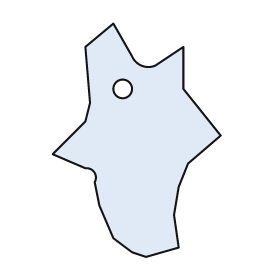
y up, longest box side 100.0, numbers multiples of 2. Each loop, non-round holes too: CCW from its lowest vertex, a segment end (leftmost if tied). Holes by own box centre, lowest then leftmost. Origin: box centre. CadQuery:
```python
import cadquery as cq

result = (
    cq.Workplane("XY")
    .moveTo(4.0, -50.0)
    .lineTo(18.0, -46.0)
    .lineTo(16.0, -32.0)
    .lineTo(18.0, -20.0)
    .lineTo(22.0, -10.0)
    .lineTo(36.0, 2.0)
    .lineTo(20.0, 22.0)
    .lineTo(20.0, 40.0)
    .lineTo(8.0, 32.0)
    .threePointArc((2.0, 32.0), (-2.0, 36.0))
    .lineTo(-10.0, 50.0)
    .lineTo(-22.0, 40.0)
    .lineTo(-20.0, 16.0)
    .lineTo(-22.0, 8.0)
    .lineTo(-36.0, -6.0)
    .lineTo(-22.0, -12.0)
    .threePointArc((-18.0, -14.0), (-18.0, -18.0))
    .lineTo(-16.0, -28.0)
    .lineTo(-10.0, -42.0)
    .lineTo(-2.0, -48.0)
    .close()
    .moveTo(-6.0, 22.0)
    .circle(4.0)
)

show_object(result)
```